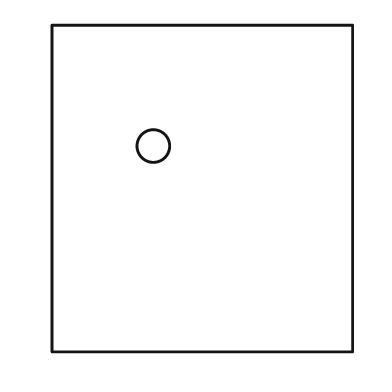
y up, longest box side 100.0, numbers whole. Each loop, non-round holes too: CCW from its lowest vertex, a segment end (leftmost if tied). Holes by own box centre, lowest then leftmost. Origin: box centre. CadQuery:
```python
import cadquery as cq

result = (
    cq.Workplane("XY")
    .moveTo(-46.0, -50.0)
    .lineTo(46.0, -50.0)
    .lineTo(46.0, 50.0)
    .lineTo(-46.0, 50.0)
    .close()
    .moveTo(-15.0, 13.0)
    .circle(5.0)
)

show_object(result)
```